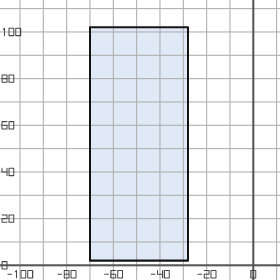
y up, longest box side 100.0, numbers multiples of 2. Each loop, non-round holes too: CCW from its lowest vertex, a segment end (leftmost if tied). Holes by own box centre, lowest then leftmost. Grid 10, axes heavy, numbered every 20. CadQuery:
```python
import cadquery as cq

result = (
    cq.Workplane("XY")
    .moveTo(-70.0, 2.0)
    .lineTo(-28.0, 2.0)
    .lineTo(-28.0, 102.0)
    .lineTo(-70.0, 102.0)
    .close()
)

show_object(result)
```